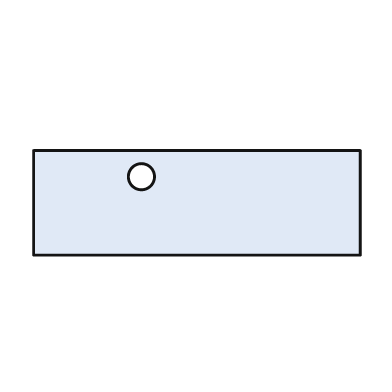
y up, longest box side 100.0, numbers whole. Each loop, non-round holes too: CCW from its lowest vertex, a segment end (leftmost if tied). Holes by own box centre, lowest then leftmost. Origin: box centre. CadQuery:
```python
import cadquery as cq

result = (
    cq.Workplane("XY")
    .moveTo(-50.0, -16.0)
    .lineTo(50.0, -16.0)
    .lineTo(50.0, 16.0)
    .lineTo(-50.0, 16.0)
    .close()
    .moveTo(-17.0, 8.0)
    .circle(4.0)
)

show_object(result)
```